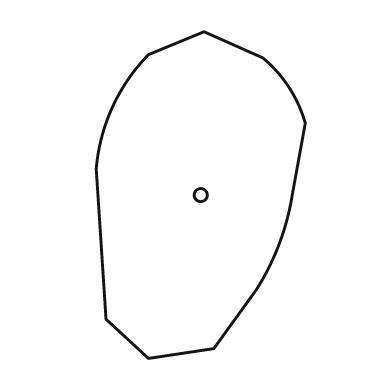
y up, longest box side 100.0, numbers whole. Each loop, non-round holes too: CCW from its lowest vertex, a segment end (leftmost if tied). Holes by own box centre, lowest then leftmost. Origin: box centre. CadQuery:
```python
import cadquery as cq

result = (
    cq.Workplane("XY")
    .moveTo(-16.0, -50.0)
    .lineTo(4.0, -47.0)
    .lineTo(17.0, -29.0)
    .threePointArc((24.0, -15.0), (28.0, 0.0))
    .lineTo(32.0, 22.0)
    .threePointArc((27.0, 33.0), (19.0, 42.0))
    .lineTo(1.0, 50.0)
    .lineTo(-16.0, 43.0)
    .threePointArc((-27.0, 27.0), (-32.0, 8.0))
    .lineTo(-29.0, -38.0)
    .close()
    .moveTo(0.0, 0.0)
    .circle(2.0)
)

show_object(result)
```